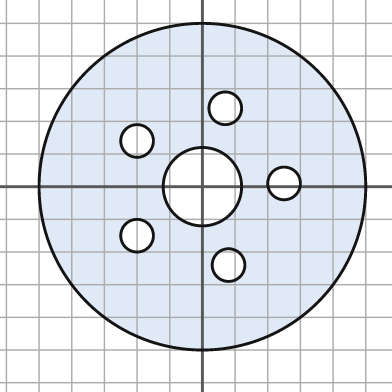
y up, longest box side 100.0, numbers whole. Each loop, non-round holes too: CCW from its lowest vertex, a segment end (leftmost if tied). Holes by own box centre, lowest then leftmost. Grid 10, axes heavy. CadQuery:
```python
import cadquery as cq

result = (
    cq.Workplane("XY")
    .moveTo(0.0, 0.0)
    .circle(50.0)
    .moveTo(8.0, -24.0)
    .circle(5.0)
    .moveTo(-20.0, -15.0)
    .circle(5.0)
    .moveTo(0.0, 0.0)
    .circle(12.0)
    .moveTo(25.0, 1.0)
    .circle(5.0)
    .moveTo(-20.0, 14.0)
    .circle(5.0)
    .moveTo(7.0, 24.0)
    .circle(5.0)
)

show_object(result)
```